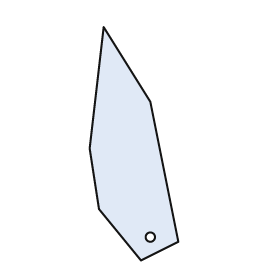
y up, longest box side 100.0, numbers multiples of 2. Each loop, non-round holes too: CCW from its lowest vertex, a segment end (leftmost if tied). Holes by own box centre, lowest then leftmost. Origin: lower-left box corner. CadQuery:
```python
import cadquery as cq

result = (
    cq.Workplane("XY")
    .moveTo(22.0, 0.0)
    .lineTo(38.0, 8.0)
    .lineTo(26.0, 68.0)
    .lineTo(6.0, 100.0)
    .lineTo(0.0, 48.0)
    .lineTo(4.0, 22.0)
    .close()
    .moveTo(26.0, 10.0)
    .circle(2.0)
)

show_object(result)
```